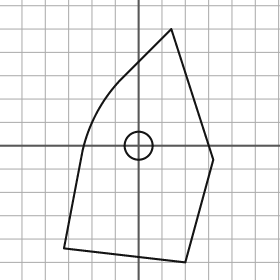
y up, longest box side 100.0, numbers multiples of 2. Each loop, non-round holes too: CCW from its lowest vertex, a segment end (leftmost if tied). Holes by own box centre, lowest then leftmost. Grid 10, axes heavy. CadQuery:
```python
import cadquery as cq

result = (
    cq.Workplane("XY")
    .moveTo(20.0, -50.0)
    .lineTo(32.0, -6.0)
    .lineTo(14.0, 50.0)
    .lineTo(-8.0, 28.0)
    .threePointArc((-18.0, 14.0), (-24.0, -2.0))
    .lineTo(-32.0, -44.0)
    .close()
    .moveTo(0.0, 0.0)
    .circle(6.0)
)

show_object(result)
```